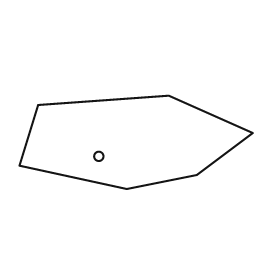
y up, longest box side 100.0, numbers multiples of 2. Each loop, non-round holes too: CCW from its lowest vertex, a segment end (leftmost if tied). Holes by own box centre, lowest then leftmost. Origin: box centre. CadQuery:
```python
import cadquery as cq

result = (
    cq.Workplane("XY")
    .moveTo(-4.0, -20.0)
    .lineTo(26.0, -14.0)
    .lineTo(50.0, 4.0)
    .lineTo(14.0, 20.0)
    .lineTo(-42.0, 16.0)
    .lineTo(-50.0, -10.0)
    .close()
    .moveTo(-16.0, -6.0)
    .circle(2.0)
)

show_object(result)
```